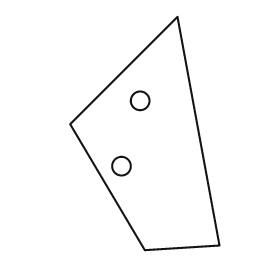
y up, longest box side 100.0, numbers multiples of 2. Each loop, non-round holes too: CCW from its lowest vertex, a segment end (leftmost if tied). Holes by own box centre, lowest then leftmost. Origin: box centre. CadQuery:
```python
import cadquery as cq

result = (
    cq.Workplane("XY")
    .moveTo(0.0, -50.0)
    .lineTo(32.0, -48.0)
    .lineTo(14.0, 50.0)
    .lineTo(-32.0, 4.0)
    .close()
    .moveTo(-10.0, -14.0)
    .circle(4.0)
    .moveTo(-2.0, 14.0)
    .circle(4.0)
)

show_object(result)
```